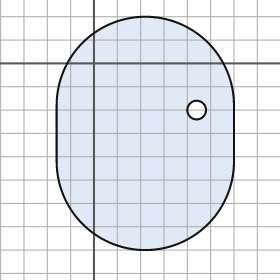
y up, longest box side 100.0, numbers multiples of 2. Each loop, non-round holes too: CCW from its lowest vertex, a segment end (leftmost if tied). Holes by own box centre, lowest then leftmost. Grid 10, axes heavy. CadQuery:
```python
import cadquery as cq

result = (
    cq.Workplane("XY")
    .moveTo(-16.0, -42.0)
    .threePointArc((22.0, -80.0), (60.0, -42.0))
    .lineTo(60.0, -18.0)
    .threePointArc((22.0, 20.0), (-16.0, -18.0))
    .close()
    .moveTo(44.0, -20.0)
    .circle(4.0)
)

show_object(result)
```